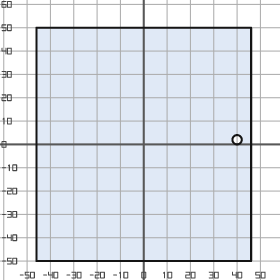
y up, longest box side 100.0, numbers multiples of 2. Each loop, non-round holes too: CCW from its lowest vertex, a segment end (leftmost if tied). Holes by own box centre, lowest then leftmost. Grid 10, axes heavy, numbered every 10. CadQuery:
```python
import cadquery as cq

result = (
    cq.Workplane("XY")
    .moveTo(-46.0, -50.0)
    .lineTo(46.0, -50.0)
    .lineTo(46.0, 50.0)
    .lineTo(-46.0, 50.0)
    .close()
    .moveTo(40.0, 2.0)
    .circle(2.0)
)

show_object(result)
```